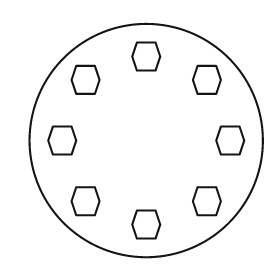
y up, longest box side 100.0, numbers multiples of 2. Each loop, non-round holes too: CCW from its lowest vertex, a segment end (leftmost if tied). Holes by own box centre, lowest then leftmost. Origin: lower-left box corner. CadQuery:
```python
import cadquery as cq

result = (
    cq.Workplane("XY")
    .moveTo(50.0, 50.0)
    .circle(50.0)
    .moveTo(46.0, 8.0)
    .lineTo(54.0, 8.0)
    .lineTo(56.0, 14.0)
    .lineTo(54.0, 20.0)
    .lineTo(46.0, 20.0)
    .lineTo(44.0, 14.0)
    .close()
    .moveTo(20.0, 18.0)
    .lineTo(28.0, 18.0)
    .lineTo(30.0, 24.0)
    .lineTo(28.0, 30.0)
    .lineTo(20.0, 30.0)
    .lineTo(18.0, 24.0)
    .close()
    .moveTo(72.0, 18.0)
    .lineTo(80.0, 18.0)
    .lineTo(82.0, 24.0)
    .lineTo(80.0, 30.0)
    .lineTo(72.0, 30.0)
    .lineTo(70.0, 24.0)
    .close()
    .moveTo(10.0, 44.0)
    .lineTo(18.0, 44.0)
    .lineTo(20.0, 50.0)
    .lineTo(18.0, 56.0)
    .lineTo(10.0, 56.0)
    .lineTo(8.0, 50.0)
    .close()
    .moveTo(82.0, 44.0)
    .lineTo(90.0, 44.0)
    .lineTo(92.0, 50.0)
    .lineTo(90.0, 56.0)
    .lineTo(82.0, 56.0)
    .lineTo(80.0, 50.0)
    .close()
    .moveTo(20.0, 70.0)
    .lineTo(28.0, 70.0)
    .lineTo(30.0, 76.0)
    .lineTo(28.0, 82.0)
    .lineTo(20.0, 82.0)
    .lineTo(18.0, 76.0)
    .close()
    .moveTo(72.0, 70.0)
    .lineTo(80.0, 70.0)
    .lineTo(82.0, 76.0)
    .lineTo(80.0, 82.0)
    .lineTo(72.0, 82.0)
    .lineTo(70.0, 76.0)
    .close()
    .moveTo(46.0, 80.0)
    .lineTo(54.0, 80.0)
    .lineTo(56.0, 86.0)
    .lineTo(54.0, 92.0)
    .lineTo(46.0, 92.0)
    .lineTo(44.0, 86.0)
    .close()
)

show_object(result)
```